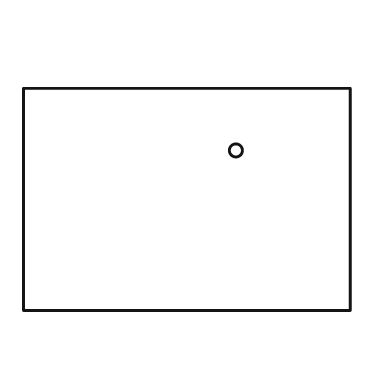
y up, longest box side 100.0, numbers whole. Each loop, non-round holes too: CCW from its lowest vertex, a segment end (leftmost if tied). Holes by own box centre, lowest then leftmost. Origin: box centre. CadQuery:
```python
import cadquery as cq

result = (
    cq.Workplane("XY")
    .moveTo(-50.0, -34.0)
    .lineTo(50.0, -34.0)
    .lineTo(50.0, 34.0)
    .lineTo(-50.0, 34.0)
    .close()
    .moveTo(15.0, 15.0)
    .circle(2.0)
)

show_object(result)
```